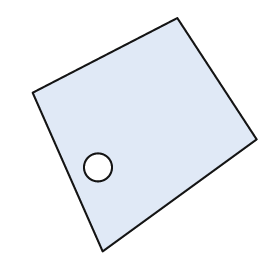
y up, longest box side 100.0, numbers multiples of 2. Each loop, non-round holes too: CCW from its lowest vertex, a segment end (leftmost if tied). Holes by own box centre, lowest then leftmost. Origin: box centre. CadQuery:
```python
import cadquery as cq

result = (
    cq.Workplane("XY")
    .moveTo(-18.0, -50.0)
    .lineTo(48.0, -2.0)
    .lineTo(14.0, 50.0)
    .lineTo(-48.0, 18.0)
    .close()
    .moveTo(-20.0, -14.0)
    .circle(6.0)
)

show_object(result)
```